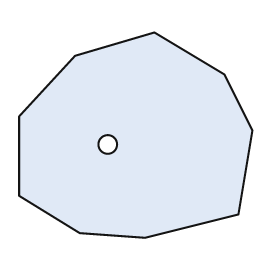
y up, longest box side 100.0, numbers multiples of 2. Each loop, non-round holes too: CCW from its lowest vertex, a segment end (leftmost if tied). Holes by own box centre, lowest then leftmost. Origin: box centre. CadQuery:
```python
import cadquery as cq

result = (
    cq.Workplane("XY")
    .moveTo(4.0, -44.0)
    .lineTo(44.0, -34.0)
    .lineTo(50.0, 2.0)
    .lineTo(38.0, 26.0)
    .lineTo(8.0, 44.0)
    .lineTo(-26.0, 34.0)
    .lineTo(-50.0, 8.0)
    .lineTo(-50.0, -26.0)
    .lineTo(-24.0, -42.0)
    .close()
    .moveTo(-12.0, -4.0)
    .circle(4.0)
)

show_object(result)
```